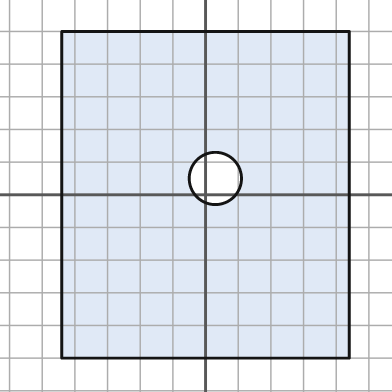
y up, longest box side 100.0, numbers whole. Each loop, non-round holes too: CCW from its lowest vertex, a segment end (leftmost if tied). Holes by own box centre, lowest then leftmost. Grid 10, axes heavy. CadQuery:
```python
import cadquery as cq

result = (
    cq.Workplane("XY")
    .moveTo(-44.0, -50.0)
    .lineTo(44.0, -50.0)
    .lineTo(44.0, 50.0)
    .lineTo(-44.0, 50.0)
    .close()
    .moveTo(3.0, 5.0)
    .circle(8.0)
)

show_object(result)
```